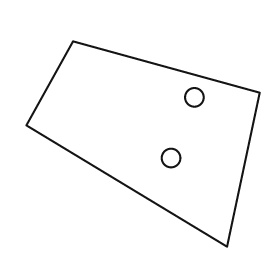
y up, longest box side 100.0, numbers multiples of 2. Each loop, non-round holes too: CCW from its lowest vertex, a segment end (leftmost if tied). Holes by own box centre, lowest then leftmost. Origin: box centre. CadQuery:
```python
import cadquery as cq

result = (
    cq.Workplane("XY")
    .moveTo(36.0, -44.0)
    .lineTo(50.0, 22.0)
    .lineTo(-30.0, 44.0)
    .lineTo(-50.0, 8.0)
    .close()
    .moveTo(12.0, -6.0)
    .circle(4.0)
    .moveTo(22.0, 20.0)
    .circle(4.0)
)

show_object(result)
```